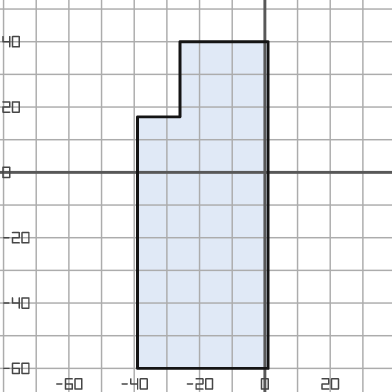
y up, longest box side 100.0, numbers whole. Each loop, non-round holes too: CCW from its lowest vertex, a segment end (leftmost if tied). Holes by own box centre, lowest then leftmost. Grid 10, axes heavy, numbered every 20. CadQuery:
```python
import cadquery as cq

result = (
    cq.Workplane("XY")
    .moveTo(-39.0, -60.0)
    .lineTo(1.0, -60.0)
    .lineTo(1.0, 40.0)
    .lineTo(-26.0, 40.0)
    .lineTo(-26.0, 17.0)
    .lineTo(-39.0, 17.0)
    .close()
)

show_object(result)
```